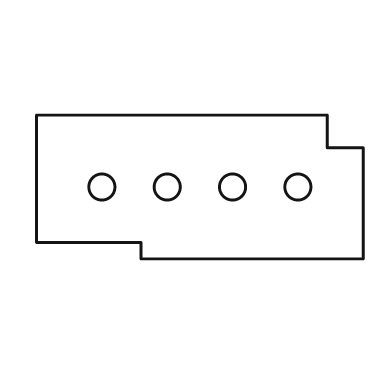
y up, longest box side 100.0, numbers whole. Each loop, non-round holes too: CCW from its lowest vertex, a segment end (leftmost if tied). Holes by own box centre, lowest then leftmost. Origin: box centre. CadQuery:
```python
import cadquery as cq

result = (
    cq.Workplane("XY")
    .moveTo(-18.0, -22.0)
    .lineTo(50.0, -22.0)
    .lineTo(50.0, 12.0)
    .lineTo(39.0, 12.0)
    .lineTo(39.0, 22.0)
    .lineTo(-50.0, 22.0)
    .lineTo(-50.0, -17.0)
    .lineTo(-18.0, -17.0)
    .close()
    .moveTo(-30.0, 0.0)
    .circle(4.0)
    .moveTo(-10.0, 0.0)
    .circle(4.0)
    .moveTo(10.0, 0.0)
    .circle(4.0)
    .moveTo(30.0, 0.0)
    .circle(4.0)
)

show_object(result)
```